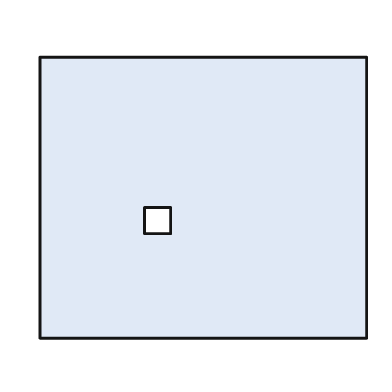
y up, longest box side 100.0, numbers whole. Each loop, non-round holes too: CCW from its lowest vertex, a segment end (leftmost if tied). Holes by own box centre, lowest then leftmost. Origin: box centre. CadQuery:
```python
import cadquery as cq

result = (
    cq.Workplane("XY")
    .moveTo(-50.0, -43.0)
    .lineTo(50.0, -43.0)
    .lineTo(50.0, 43.0)
    .lineTo(-50.0, 43.0)
    .close()
    .moveTo(-18.0, -11.0)
    .lineTo(-10.0, -11.0)
    .lineTo(-10.0, -3.0)
    .lineTo(-18.0, -3.0)
    .close()
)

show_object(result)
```